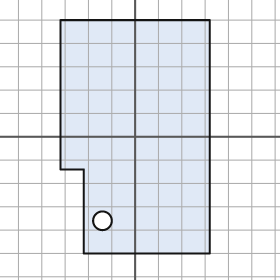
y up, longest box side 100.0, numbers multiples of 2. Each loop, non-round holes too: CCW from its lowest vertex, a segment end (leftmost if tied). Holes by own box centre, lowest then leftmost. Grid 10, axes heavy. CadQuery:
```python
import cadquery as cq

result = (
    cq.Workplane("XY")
    .moveTo(-22.0, -50.0)
    .lineTo(32.0, -50.0)
    .lineTo(32.0, 50.0)
    .lineTo(-32.0, 50.0)
    .lineTo(-32.0, -14.0)
    .lineTo(-22.0, -14.0)
    .close()
    .moveTo(-14.0, -36.0)
    .circle(4.0)
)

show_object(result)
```